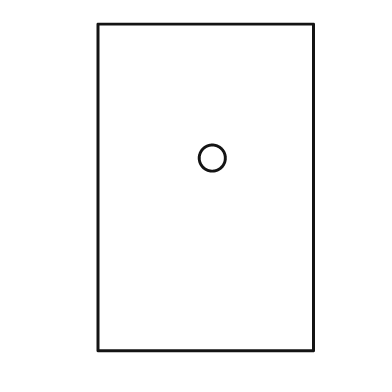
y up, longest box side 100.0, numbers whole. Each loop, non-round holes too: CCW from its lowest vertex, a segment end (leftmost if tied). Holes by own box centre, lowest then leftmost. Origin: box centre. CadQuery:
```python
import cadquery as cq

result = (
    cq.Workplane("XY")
    .moveTo(-33.0, -50.0)
    .lineTo(33.0, -50.0)
    .lineTo(33.0, 50.0)
    .lineTo(-33.0, 50.0)
    .close()
    .moveTo(2.0, 9.0)
    .circle(4.0)
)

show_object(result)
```